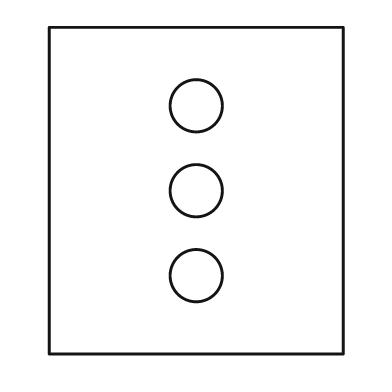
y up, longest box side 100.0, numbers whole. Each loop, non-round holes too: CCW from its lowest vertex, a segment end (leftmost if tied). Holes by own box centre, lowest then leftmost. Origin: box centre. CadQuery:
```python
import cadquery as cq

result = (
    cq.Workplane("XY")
    .moveTo(-45.0, -50.0)
    .lineTo(45.0, -50.0)
    .lineTo(45.0, 50.0)
    .lineTo(-45.0, 50.0)
    .close()
    .moveTo(0.0, -26.0)
    .circle(8.0)
    .moveTo(0.0, 0.0)
    .circle(8.0)
    .moveTo(0.0, 26.0)
    .circle(8.0)
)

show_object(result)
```